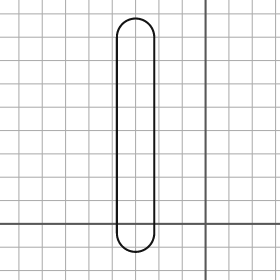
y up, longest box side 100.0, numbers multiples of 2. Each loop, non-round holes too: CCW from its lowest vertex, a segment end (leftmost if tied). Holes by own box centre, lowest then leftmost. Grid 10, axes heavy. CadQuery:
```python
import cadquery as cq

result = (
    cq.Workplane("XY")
    .moveTo(-38.0, -4.0)
    .threePointArc((-30.0, -12.0), (-22.0, -4.0))
    .lineTo(-22.0, 80.0)
    .threePointArc((-30.0, 88.0), (-38.0, 80.0))
    .close()
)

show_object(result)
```